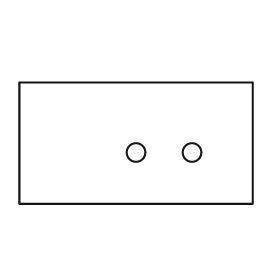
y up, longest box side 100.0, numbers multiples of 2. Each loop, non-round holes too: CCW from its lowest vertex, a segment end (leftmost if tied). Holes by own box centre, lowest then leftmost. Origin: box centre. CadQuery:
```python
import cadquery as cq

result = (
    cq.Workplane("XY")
    .moveTo(-50.0, -26.0)
    .lineTo(50.0, -26.0)
    .lineTo(50.0, 26.0)
    .lineTo(-50.0, 26.0)
    .close()
    .moveTo(0.0, -4.0)
    .circle(4.0)
    .moveTo(24.0, -4.0)
    .circle(4.0)
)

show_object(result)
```